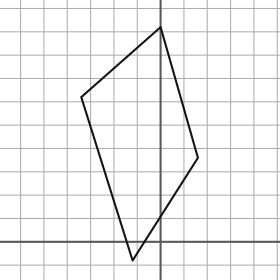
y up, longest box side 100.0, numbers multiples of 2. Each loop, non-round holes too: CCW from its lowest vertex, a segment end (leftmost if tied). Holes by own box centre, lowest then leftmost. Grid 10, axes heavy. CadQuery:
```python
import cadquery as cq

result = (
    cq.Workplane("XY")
    .moveTo(-12.0, -8.0)
    .lineTo(16.0, 36.0)
    .lineTo(0.0, 92.0)
    .lineTo(-34.0, 62.0)
    .close()
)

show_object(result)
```